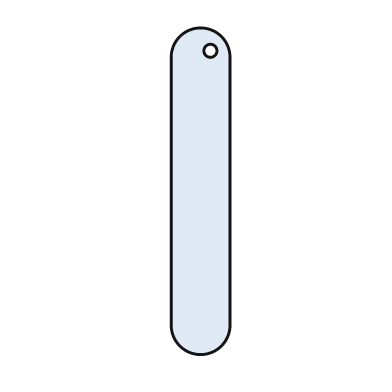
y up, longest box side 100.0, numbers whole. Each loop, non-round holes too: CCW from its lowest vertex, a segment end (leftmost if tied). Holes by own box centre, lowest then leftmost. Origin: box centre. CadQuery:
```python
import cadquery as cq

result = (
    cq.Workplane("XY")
    .moveTo(-9.0, -41.0)
    .threePointArc((0.0, -50.0), (9.0, -41.0))
    .lineTo(9.0, 41.0)
    .threePointArc((0.0, 50.0), (-9.0, 41.0))
    .close()
    .moveTo(3.0, 43.0)
    .circle(2.0)
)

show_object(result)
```